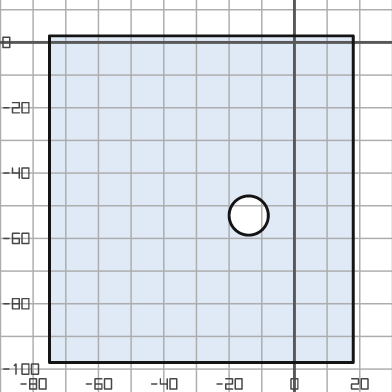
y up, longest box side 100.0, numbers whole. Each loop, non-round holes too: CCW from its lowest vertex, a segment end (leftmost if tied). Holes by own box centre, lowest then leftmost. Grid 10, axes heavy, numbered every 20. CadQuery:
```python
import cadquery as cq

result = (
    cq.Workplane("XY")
    .moveTo(-75.0, -98.0)
    .lineTo(18.0, -98.0)
    .lineTo(18.0, 2.0)
    .lineTo(-75.0, 2.0)
    .close()
    .moveTo(-14.0, -53.0)
    .circle(6.0)
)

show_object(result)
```